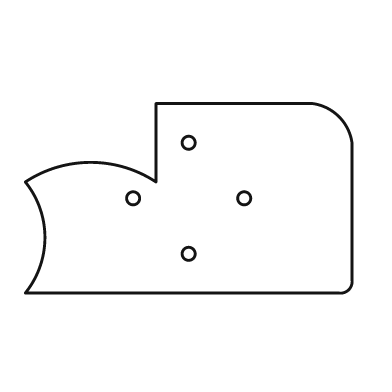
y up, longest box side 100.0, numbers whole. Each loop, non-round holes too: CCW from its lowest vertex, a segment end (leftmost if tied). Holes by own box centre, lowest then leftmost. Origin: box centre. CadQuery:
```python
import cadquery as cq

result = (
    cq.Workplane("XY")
    .moveTo(-50.0, -29.0)
    .lineTo(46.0, -29.0)
    .threePointArc((49.0, -28.0), (50.0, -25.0))
    .lineTo(50.0, 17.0)
    .threePointArc((46.0, 25.0), (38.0, 29.0))
    .lineTo(-10.0, 29.0)
    .lineTo(-10.0, 5.0)
    .threePointArc((-30.0, 11.0), (-50.0, 5.0))
    .threePointArc((-44.0, -12.0), (-50.0, -29.0))
    .close()
    .moveTo(0.0, -17.0)
    .circle(2.0)
    .moveTo(-17.0, 0.0)
    .circle(2.0)
    .moveTo(17.0, 0.0)
    .circle(2.0)
    .moveTo(0.0, 17.0)
    .circle(2.0)
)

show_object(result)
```